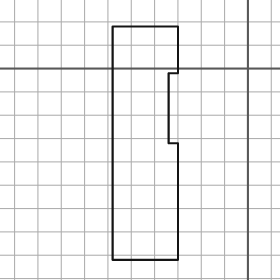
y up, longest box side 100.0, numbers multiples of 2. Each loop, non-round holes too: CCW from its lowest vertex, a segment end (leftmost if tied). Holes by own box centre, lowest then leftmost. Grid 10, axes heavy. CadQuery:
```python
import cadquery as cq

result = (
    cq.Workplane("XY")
    .moveTo(-58.0, -82.0)
    .lineTo(-30.0, -82.0)
    .lineTo(-30.0, -32.0)
    .lineTo(-34.0, -32.0)
    .lineTo(-34.0, -2.0)
    .lineTo(-30.0, -2.0)
    .lineTo(-30.0, 18.0)
    .lineTo(-58.0, 18.0)
    .close()
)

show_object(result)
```